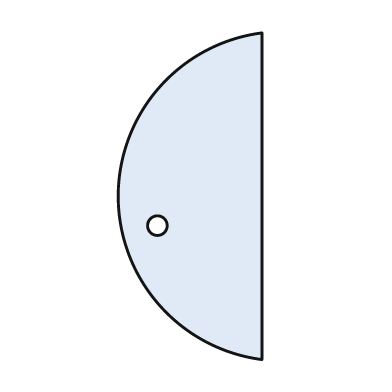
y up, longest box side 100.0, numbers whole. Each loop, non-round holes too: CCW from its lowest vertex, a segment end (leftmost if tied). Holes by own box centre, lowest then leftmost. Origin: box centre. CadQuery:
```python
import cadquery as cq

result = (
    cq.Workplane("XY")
    .moveTo(22.0, -50.0)
    .lineTo(22.0, 50.0)
    .threePointArc((-22.0, 0.0), (22.0, -50.0))
    .close()
    .moveTo(-10.0, -9.0)
    .circle(3.0)
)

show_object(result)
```